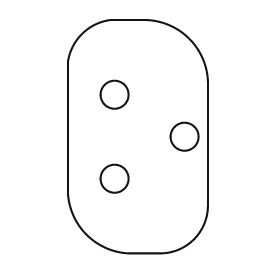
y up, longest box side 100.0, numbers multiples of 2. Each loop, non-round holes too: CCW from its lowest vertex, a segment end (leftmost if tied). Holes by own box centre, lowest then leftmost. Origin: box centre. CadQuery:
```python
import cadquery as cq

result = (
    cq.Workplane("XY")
    .moveTo(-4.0, -50.0)
    .lineTo(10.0, -50.0)
    .threePointArc((24.0, -44.0), (30.0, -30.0))
    .lineTo(30.0, 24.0)
    .threePointArc((22.0, 42.0), (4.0, 50.0))
    .lineTo(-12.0, 50.0)
    .threePointArc((-24.0, 44.0), (-30.0, 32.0))
    .lineTo(-30.0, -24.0)
    .threePointArc((-22.0, -42.0), (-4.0, -50.0))
    .close()
    .moveTo(-10.0, -18.0)
    .circle(6.0)
    .moveTo(20.0, 0.0)
    .circle(6.0)
    .moveTo(-10.0, 18.0)
    .circle(6.0)
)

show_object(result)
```